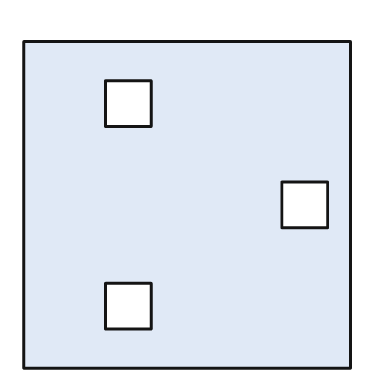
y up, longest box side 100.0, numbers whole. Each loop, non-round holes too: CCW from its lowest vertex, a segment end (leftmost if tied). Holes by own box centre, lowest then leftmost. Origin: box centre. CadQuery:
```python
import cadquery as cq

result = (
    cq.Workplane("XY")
    .moveTo(-50.0, -50.0)
    .lineTo(50.0, -50.0)
    .lineTo(50.0, 50.0)
    .lineTo(-50.0, 50.0)
    .close()
    .moveTo(-25.0, -38.0)
    .lineTo(-11.0, -38.0)
    .lineTo(-11.0, -24.0)
    .lineTo(-25.0, -24.0)
    .close()
    .moveTo(29.0, -7.0)
    .lineTo(43.0, -7.0)
    .lineTo(43.0, 7.0)
    .lineTo(29.0, 7.0)
    .close()
    .moveTo(-25.0, 24.0)
    .lineTo(-11.0, 24.0)
    .lineTo(-11.0, 38.0)
    .lineTo(-25.0, 38.0)
    .close()
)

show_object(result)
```